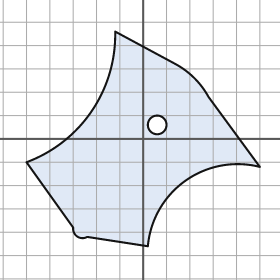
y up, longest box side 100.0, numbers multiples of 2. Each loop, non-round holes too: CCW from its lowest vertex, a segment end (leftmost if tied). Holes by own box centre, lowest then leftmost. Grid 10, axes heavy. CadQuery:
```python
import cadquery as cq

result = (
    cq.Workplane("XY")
    .moveTo(2.0, -46.0)
    .threePointArc((18.0, -18.0), (50.0, -12.0))
    .lineTo(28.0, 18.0)
    .threePointArc((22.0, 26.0), (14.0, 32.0))
    .lineTo(-12.0, 46.0)
    .threePointArc((-22.0, 12.0), (-50.0, -10.0))
    .lineTo(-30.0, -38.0)
    .threePointArc((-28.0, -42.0), (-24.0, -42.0))
    .close()
    .moveTo(6.0, 6.0)
    .circle(4.0)
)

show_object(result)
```